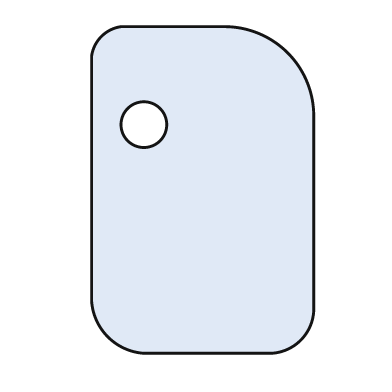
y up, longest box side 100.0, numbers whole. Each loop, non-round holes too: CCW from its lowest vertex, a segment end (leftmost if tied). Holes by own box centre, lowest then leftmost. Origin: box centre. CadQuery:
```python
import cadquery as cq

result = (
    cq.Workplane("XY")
    .moveTo(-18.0, -50.0)
    .lineTo(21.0, -50.0)
    .threePointArc((30.0, -46.0), (34.0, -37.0))
    .lineTo(34.0, 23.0)
    .threePointArc((26.0, 42.0), (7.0, 50.0))
    .lineTo(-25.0, 50.0)
    .threePointArc((-31.0, 47.0), (-34.0, 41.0))
    .lineTo(-34.0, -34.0)
    .threePointArc((-29.0, -45.0), (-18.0, -50.0))
    .close()
    .moveTo(-18.0, 20.0)
    .circle(7.0)
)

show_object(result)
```